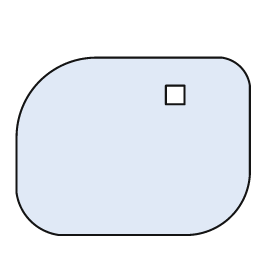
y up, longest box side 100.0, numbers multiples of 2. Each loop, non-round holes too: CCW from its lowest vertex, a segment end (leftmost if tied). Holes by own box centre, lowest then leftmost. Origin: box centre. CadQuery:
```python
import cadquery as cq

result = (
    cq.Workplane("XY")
    .moveTo(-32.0, -38.0)
    .lineTo(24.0, -38.0)
    .threePointArc((42.0, -30.0), (50.0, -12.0))
    .lineTo(50.0, 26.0)
    .threePointArc((46.0, 34.0), (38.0, 38.0))
    .lineTo(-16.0, 38.0)
    .threePointArc((-40.0, 28.0), (-50.0, 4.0))
    .lineTo(-50.0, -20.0)
    .threePointArc((-44.0, -32.0), (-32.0, -38.0))
    .close()
    .moveTo(14.0, 18.0)
    .lineTo(22.0, 18.0)
    .lineTo(22.0, 26.0)
    .lineTo(14.0, 26.0)
    .close()
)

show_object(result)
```